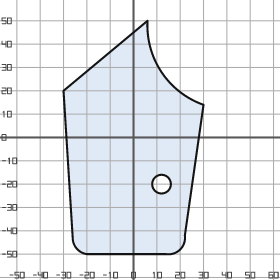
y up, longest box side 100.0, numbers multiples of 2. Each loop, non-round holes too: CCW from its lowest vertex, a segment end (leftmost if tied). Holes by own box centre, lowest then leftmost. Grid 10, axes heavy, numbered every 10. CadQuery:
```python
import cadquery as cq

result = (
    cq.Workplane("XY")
    .moveTo(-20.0, -50.0)
    .lineTo(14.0, -50.0)
    .threePointArc((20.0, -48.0), (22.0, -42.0))
    .lineTo(30.0, 14.0)
    .threePointArc((12.0, 28.0), (6.0, 50.0))
    .lineTo(-30.0, 20.0)
    .lineTo(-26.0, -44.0)
    .threePointArc((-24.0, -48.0), (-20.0, -50.0))
    .close()
    .moveTo(12.0, -20.0)
    .circle(4.0)
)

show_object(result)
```